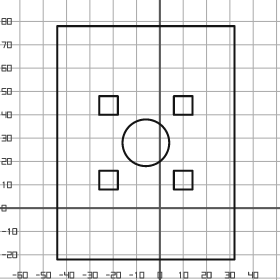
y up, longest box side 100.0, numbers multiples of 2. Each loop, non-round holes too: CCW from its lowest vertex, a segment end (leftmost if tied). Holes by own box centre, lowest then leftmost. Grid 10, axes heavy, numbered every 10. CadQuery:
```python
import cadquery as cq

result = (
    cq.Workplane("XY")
    .moveTo(-44.0, -22.0)
    .lineTo(32.0, -22.0)
    .lineTo(32.0, 78.0)
    .lineTo(-44.0, 78.0)
    .close()
    .moveTo(-26.0, 8.0)
    .lineTo(-18.0, 8.0)
    .lineTo(-18.0, 16.0)
    .lineTo(-26.0, 16.0)
    .close()
    .moveTo(6.0, 8.0)
    .lineTo(14.0, 8.0)
    .lineTo(14.0, 16.0)
    .lineTo(6.0, 16.0)
    .close()
    .moveTo(-6.0, 28.0)
    .circle(10.0)
    .moveTo(-26.0, 40.0)
    .lineTo(-18.0, 40.0)
    .lineTo(-18.0, 48.0)
    .lineTo(-26.0, 48.0)
    .close()
    .moveTo(6.0, 40.0)
    .lineTo(14.0, 40.0)
    .lineTo(14.0, 48.0)
    .lineTo(6.0, 48.0)
    .close()
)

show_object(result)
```